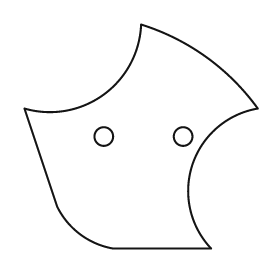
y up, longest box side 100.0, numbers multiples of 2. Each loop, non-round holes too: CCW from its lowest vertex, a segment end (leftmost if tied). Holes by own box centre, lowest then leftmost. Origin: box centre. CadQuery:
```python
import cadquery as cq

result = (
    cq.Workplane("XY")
    .moveTo(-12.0, -48.0)
    .lineTo(30.0, -48.0)
    .threePointArc((22.0, -12.0), (50.0, 12.0))
    .threePointArc((28.0, 34.0), (0.0, 48.0))
    .threePointArc((-16.0, 18.0), (-50.0, 12.0))
    .lineTo(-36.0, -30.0)
    .threePointArc((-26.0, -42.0), (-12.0, -48.0))
    .close()
    .moveTo(-16.0, 0.0)
    .circle(4.0)
    .moveTo(18.0, 0.0)
    .circle(4.0)
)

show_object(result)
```